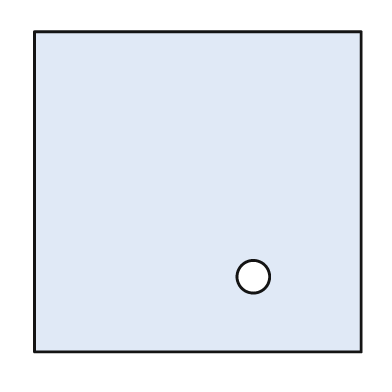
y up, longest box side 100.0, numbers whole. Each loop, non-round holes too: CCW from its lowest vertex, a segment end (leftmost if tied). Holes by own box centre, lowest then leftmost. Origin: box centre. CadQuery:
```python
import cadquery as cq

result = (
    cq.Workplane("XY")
    .moveTo(-50.0, -49.0)
    .lineTo(50.0, -49.0)
    .lineTo(50.0, 49.0)
    .lineTo(-50.0, 49.0)
    .close()
    .moveTo(17.0, -26.0)
    .circle(5.0)
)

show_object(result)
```